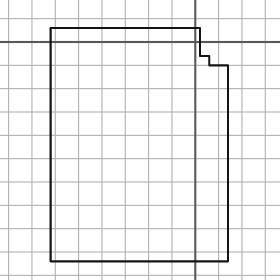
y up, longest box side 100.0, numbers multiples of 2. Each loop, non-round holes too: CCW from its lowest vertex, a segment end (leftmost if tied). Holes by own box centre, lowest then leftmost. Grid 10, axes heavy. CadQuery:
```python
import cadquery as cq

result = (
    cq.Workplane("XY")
    .moveTo(-62.0, -94.0)
    .lineTo(14.0, -94.0)
    .lineTo(14.0, -10.0)
    .lineTo(6.0, -10.0)
    .lineTo(6.0, -6.0)
    .lineTo(2.0, -6.0)
    .lineTo(2.0, 6.0)
    .lineTo(-62.0, 6.0)
    .close()
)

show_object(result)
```